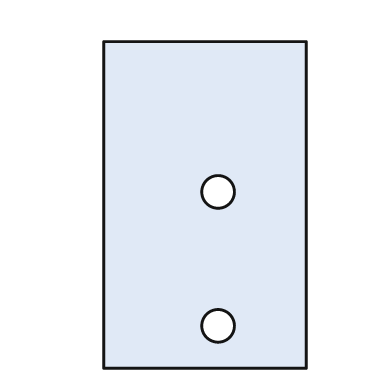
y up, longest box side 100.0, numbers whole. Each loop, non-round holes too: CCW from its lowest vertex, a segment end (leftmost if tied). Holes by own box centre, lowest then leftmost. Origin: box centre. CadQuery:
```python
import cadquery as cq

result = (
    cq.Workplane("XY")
    .moveTo(-31.0, -50.0)
    .lineTo(31.0, -50.0)
    .lineTo(31.0, 50.0)
    .lineTo(-31.0, 50.0)
    .close()
    .moveTo(4.0, -37.0)
    .circle(5.0)
    .moveTo(4.0, 4.0)
    .circle(5.0)
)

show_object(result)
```